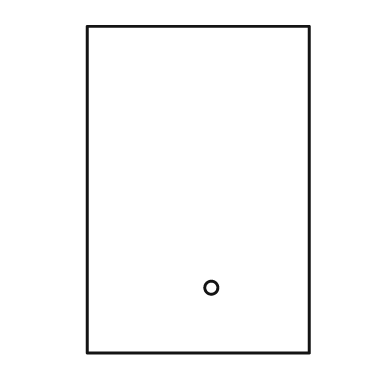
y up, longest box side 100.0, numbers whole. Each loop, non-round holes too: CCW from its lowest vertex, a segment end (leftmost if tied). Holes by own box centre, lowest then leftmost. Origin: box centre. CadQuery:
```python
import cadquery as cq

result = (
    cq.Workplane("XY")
    .moveTo(-34.0, -50.0)
    .lineTo(34.0, -50.0)
    .lineTo(34.0, 50.0)
    .lineTo(-34.0, 50.0)
    .close()
    .moveTo(4.0, -30.0)
    .circle(2.0)
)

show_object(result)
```